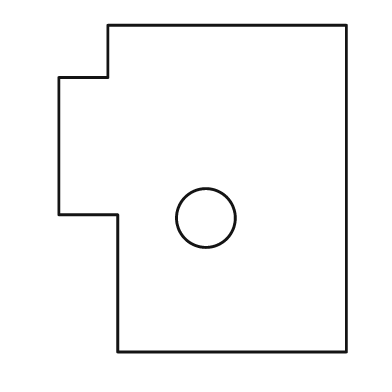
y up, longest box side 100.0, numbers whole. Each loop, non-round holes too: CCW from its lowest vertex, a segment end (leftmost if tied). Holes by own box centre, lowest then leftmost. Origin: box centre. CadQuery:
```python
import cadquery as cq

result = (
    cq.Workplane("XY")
    .moveTo(-26.0, -50.0)
    .lineTo(44.0, -50.0)
    .lineTo(44.0, 50.0)
    .lineTo(-29.0, 50.0)
    .lineTo(-29.0, 34.0)
    .lineTo(-44.0, 34.0)
    .lineTo(-44.0, -8.0)
    .lineTo(-26.0, -8.0)
    .close()
    .moveTo(1.0, -9.0)
    .circle(9.0)
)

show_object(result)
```